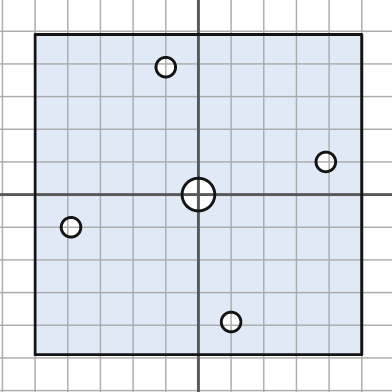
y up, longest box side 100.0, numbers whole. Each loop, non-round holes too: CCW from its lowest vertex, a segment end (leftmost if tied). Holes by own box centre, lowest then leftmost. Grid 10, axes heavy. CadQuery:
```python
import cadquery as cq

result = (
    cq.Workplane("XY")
    .moveTo(-50.0, -49.0)
    .lineTo(50.0, -49.0)
    .lineTo(50.0, 49.0)
    .lineTo(-50.0, 49.0)
    .close()
    .moveTo(10.0, -39.0)
    .circle(3.0)
    .moveTo(-39.0, -10.0)
    .circle(3.0)
    .moveTo(0.0, 0.0)
    .circle(5.0)
    .moveTo(39.0, 10.0)
    .circle(3.0)
    .moveTo(-10.0, 39.0)
    .circle(3.0)
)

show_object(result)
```